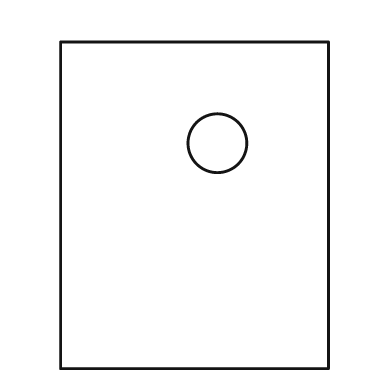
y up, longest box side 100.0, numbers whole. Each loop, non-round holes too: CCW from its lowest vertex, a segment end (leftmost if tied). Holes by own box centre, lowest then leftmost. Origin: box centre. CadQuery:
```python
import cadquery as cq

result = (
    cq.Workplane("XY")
    .moveTo(-41.0, -50.0)
    .lineTo(41.0, -50.0)
    .lineTo(41.0, 50.0)
    .lineTo(-41.0, 50.0)
    .close()
    .moveTo(7.0, 19.0)
    .circle(9.0)
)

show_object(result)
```